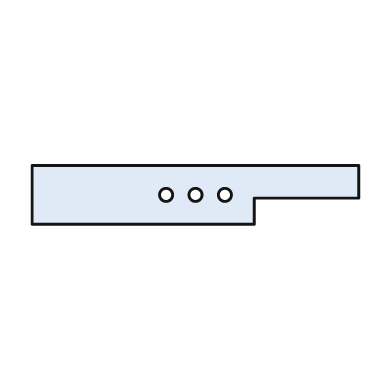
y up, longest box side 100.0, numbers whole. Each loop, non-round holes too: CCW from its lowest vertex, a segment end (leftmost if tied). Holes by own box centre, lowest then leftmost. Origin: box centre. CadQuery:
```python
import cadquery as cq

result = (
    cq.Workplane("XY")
    .moveTo(-50.0, -9.0)
    .lineTo(18.0, -9.0)
    .lineTo(18.0, -1.0)
    .lineTo(50.0, -1.0)
    .lineTo(50.0, 9.0)
    .lineTo(-50.0, 9.0)
    .close()
    .moveTo(-9.0, 0.0)
    .circle(2.0)
    .moveTo(0.0, 0.0)
    .circle(2.0)
    .moveTo(9.0, 0.0)
    .circle(2.0)
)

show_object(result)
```